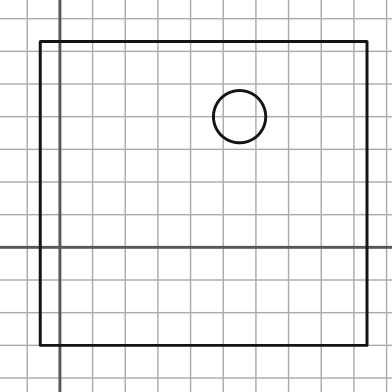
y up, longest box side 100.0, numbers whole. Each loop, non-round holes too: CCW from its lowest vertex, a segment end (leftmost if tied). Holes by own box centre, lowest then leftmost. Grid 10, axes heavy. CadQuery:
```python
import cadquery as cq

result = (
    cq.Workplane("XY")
    .moveTo(-6.0, -30.0)
    .lineTo(94.0, -30.0)
    .lineTo(94.0, 63.0)
    .lineTo(-6.0, 63.0)
    .close()
    .moveTo(55.0, 40.0)
    .circle(8.0)
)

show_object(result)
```